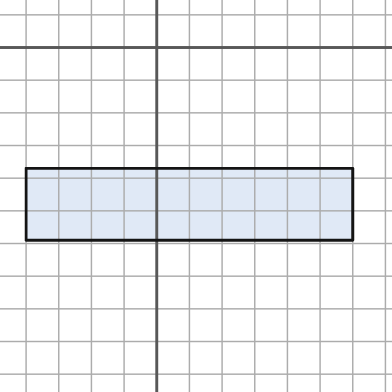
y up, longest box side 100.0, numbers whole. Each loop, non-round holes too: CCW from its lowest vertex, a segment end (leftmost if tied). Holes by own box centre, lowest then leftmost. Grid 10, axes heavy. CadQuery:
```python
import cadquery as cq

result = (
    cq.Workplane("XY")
    .moveTo(-40.0, -59.0)
    .lineTo(60.0, -59.0)
    .lineTo(60.0, -37.0)
    .lineTo(-40.0, -37.0)
    .close()
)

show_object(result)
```